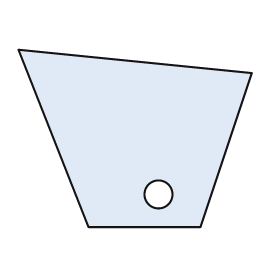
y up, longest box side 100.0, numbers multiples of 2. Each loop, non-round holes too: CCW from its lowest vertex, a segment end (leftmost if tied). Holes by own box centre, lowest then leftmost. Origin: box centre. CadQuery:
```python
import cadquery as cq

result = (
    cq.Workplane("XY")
    .moveTo(-20.0, -38.0)
    .lineTo(28.0, -38.0)
    .lineTo(50.0, 28.0)
    .lineTo(-50.0, 38.0)
    .close()
    .moveTo(10.0, -24.0)
    .circle(6.0)
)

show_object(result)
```